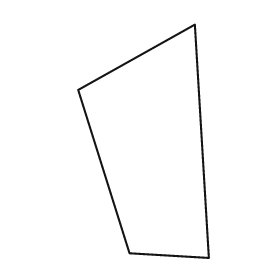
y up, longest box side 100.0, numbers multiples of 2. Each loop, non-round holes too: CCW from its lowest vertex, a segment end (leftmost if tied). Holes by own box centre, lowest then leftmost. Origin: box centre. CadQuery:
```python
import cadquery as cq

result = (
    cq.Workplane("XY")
    .moveTo(28.0, -50.0)
    .lineTo(22.0, 50.0)
    .lineTo(-28.0, 22.0)
    .lineTo(-6.0, -48.0)
    .close()
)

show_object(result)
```